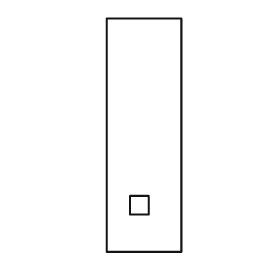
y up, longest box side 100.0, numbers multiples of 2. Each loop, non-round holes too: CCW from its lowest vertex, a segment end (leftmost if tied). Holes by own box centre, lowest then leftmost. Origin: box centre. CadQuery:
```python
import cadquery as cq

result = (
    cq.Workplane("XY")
    .moveTo(-16.0, -50.0)
    .lineTo(16.0, -50.0)
    .lineTo(16.0, 50.0)
    .lineTo(-16.0, 50.0)
    .close()
    .moveTo(-6.0, -34.0)
    .lineTo(2.0, -34.0)
    .lineTo(2.0, -26.0)
    .lineTo(-6.0, -26.0)
    .close()
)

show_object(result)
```